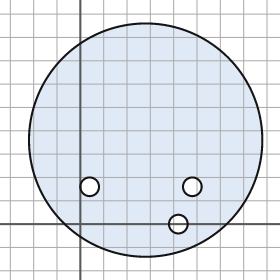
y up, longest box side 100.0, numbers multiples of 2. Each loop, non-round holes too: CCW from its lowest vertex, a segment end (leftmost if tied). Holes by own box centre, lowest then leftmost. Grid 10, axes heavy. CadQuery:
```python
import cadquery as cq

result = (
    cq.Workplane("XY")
    .moveTo(28.0, 36.0)
    .circle(50.0)
    .moveTo(42.0, 0.0)
    .circle(4.0)
    .moveTo(4.0, 16.0)
    .circle(4.0)
    .moveTo(48.0, 16.0)
    .circle(4.0)
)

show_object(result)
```